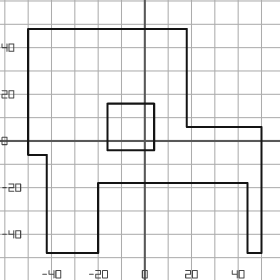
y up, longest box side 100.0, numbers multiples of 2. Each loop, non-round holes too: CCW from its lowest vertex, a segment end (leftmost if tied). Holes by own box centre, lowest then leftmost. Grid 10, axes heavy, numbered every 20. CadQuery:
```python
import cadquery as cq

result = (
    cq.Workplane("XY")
    .moveTo(-42.0, -48.0)
    .lineTo(-20.0, -48.0)
    .lineTo(-20.0, -18.0)
    .lineTo(44.0, -18.0)
    .lineTo(44.0, -48.0)
    .lineTo(50.0, -48.0)
    .lineTo(50.0, 6.0)
    .lineTo(18.0, 6.0)
    .lineTo(18.0, 48.0)
    .lineTo(-50.0, 48.0)
    .lineTo(-50.0, -6.0)
    .lineTo(-42.0, -6.0)
    .close()
    .moveTo(-16.0, -4.0)
    .lineTo(4.0, -4.0)
    .lineTo(4.0, 16.0)
    .lineTo(-16.0, 16.0)
    .close()
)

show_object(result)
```